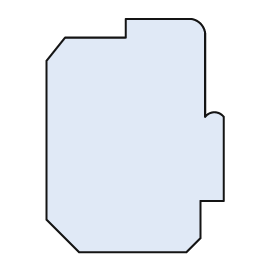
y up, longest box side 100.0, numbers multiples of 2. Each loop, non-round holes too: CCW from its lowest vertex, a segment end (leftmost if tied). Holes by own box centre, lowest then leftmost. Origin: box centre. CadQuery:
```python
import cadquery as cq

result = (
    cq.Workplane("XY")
    .moveTo(-24.0, -50.0)
    .lineTo(22.0, -50.0)
    .lineTo(28.0, -44.0)
    .lineTo(28.0, -28.0)
    .lineTo(38.0, -28.0)
    .lineTo(38.0, 8.0)
    .threePointArc((34.0, 10.0), (30.0, 8.0))
    .lineTo(30.0, 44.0)
    .threePointArc((28.0, 48.0), (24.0, 50.0))
    .lineTo(-4.0, 50.0)
    .lineTo(-4.0, 42.0)
    .lineTo(-30.0, 42.0)
    .lineTo(-38.0, 32.0)
    .lineTo(-38.0, -36.0)
    .close()
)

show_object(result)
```